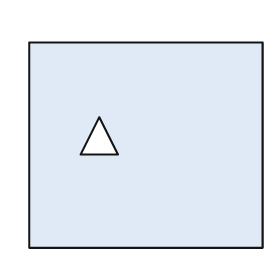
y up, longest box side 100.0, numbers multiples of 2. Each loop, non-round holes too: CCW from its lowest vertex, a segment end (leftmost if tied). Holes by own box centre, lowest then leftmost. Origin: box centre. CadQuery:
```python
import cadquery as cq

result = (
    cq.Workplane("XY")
    .moveTo(-50.0, -44.0)
    .lineTo(50.0, -44.0)
    .lineTo(50.0, 44.0)
    .lineTo(-50.0, 44.0)
    .close()
    .moveTo(-28.0, -4.0)
    .lineTo(-12.0, -4.0)
    .lineTo(-20.0, 12.0)
    .close()
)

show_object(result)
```